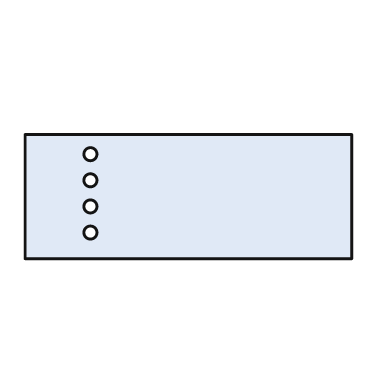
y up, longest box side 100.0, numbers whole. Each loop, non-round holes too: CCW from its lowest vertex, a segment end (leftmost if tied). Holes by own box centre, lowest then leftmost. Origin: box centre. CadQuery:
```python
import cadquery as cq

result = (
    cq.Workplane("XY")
    .moveTo(-50.0, -19.0)
    .lineTo(50.0, -19.0)
    .lineTo(50.0, 19.0)
    .lineTo(-50.0, 19.0)
    .close()
    .moveTo(-30.0, -11.0)
    .circle(2.0)
    .moveTo(-30.0, -3.0)
    .circle(2.0)
    .moveTo(-30.0, 5.0)
    .circle(2.0)
    .moveTo(-30.0, 13.0)
    .circle(2.0)
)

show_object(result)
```